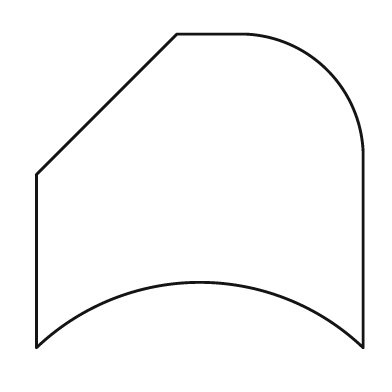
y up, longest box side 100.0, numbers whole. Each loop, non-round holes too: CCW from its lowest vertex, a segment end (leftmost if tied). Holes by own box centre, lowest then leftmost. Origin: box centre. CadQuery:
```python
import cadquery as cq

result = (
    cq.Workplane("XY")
    .moveTo(-50.0, -48.0)
    .threePointArc((0.0, -28.0), (50.0, -48.0))
    .lineTo(50.0, 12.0)
    .threePointArc((39.0, 37.0), (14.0, 48.0))
    .lineTo(-7.0, 48.0)
    .lineTo(-50.0, 5.0)
    .close()
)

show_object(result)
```